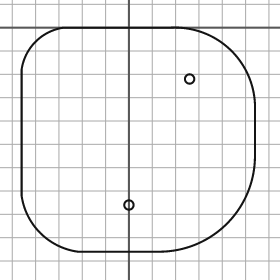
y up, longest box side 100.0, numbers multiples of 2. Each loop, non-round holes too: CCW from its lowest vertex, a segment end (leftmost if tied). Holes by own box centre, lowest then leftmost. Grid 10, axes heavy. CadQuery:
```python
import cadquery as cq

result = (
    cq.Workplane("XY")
    .moveTo(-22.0, -96.0)
    .lineTo(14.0, -96.0)
    .threePointArc((42.0, -84.0), (54.0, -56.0))
    .lineTo(54.0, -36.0)
    .threePointArc((44.0, -10.0), (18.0, 0.0))
    .lineTo(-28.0, 0.0)
    .threePointArc((-40.0, -6.0), (-46.0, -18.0))
    .lineTo(-46.0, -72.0)
    .threePointArc((-38.0, -88.0), (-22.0, -96.0))
    .close()
    .moveTo(0.0, -76.0)
    .circle(2.0)
    .moveTo(26.0, -22.0)
    .circle(2.0)
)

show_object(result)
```